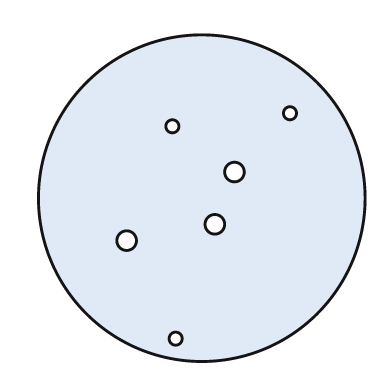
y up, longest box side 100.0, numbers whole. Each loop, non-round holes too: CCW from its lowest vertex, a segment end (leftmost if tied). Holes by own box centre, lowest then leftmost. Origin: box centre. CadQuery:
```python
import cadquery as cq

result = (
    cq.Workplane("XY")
    .moveTo(0.0, 0.0)
    .circle(50.0)
    .moveTo(-8.0, -43.0)
    .circle(2.0)
    .moveTo(-23.0, -13.0)
    .circle(3.0)
    .moveTo(4.0, -8.0)
    .circle(3.0)
    .moveTo(10.0, 8.0)
    .circle(3.0)
    .moveTo(-9.0, 22.0)
    .circle(2.0)
    .moveTo(27.0, 26.0)
    .circle(2.0)
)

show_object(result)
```